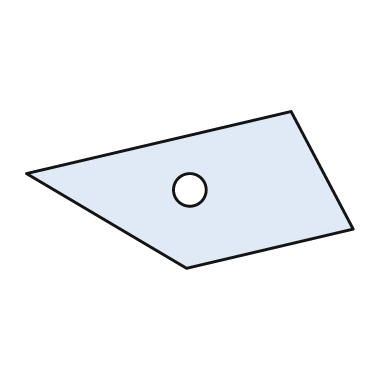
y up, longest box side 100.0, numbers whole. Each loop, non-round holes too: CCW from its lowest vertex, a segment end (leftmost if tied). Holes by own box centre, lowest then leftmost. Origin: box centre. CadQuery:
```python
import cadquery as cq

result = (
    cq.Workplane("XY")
    .moveTo(-1.0, -24.0)
    .lineTo(50.0, -12.0)
    .lineTo(31.0, 24.0)
    .lineTo(-50.0, 5.0)
    .close()
    .moveTo(0.0, 0.0)
    .circle(5.0)
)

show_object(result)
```